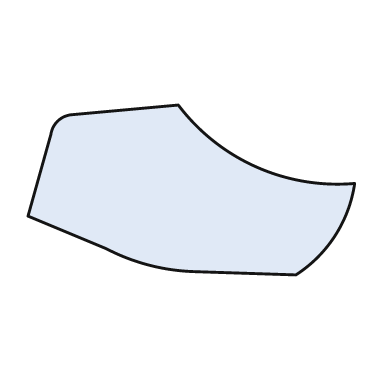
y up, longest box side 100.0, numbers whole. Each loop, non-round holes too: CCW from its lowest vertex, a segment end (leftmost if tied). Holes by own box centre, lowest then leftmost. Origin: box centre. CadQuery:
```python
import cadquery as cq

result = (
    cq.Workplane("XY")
    .moveTo(32.0, -26.0)
    .threePointArc((44.0, -14.0), (50.0, 2.0))
    .threePointArc((20.0, 7.0), (-4.0, 26.0))
    .lineTo(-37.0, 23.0)
    .threePointArc((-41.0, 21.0), (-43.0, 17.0))
    .lineTo(-50.0, -8.0)
    .lineTo(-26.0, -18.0)
    .threePointArc((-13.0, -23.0), (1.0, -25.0))
    .close()
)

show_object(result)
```